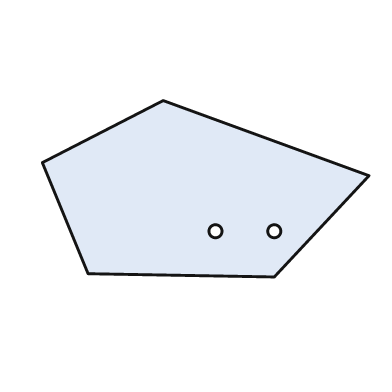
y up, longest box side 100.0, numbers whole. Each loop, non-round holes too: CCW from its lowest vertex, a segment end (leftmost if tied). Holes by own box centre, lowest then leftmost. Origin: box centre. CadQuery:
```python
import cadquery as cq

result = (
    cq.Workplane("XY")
    .moveTo(21.0, -27.0)
    .lineTo(50.0, 4.0)
    .lineTo(-13.0, 27.0)
    .lineTo(-50.0, 8.0)
    .lineTo(-36.0, -26.0)
    .close()
    .moveTo(3.0, -13.0)
    .circle(2.0)
    .moveTo(21.0, -13.0)
    .circle(2.0)
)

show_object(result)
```